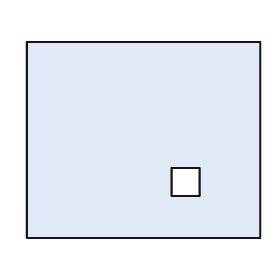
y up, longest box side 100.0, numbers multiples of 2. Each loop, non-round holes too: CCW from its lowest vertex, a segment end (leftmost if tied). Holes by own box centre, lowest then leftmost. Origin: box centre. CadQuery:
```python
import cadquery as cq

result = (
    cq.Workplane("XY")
    .moveTo(-50.0, -42.0)
    .lineTo(50.0, -42.0)
    .lineTo(50.0, 42.0)
    .lineTo(-50.0, 42.0)
    .close()
    .moveTo(12.0, -24.0)
    .lineTo(24.0, -24.0)
    .lineTo(24.0, -12.0)
    .lineTo(12.0, -12.0)
    .close()
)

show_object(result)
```